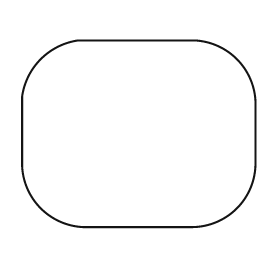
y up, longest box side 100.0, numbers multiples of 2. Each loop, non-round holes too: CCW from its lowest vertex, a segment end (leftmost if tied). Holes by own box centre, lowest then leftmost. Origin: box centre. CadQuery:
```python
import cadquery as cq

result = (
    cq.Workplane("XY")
    .moveTo(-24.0, -40.0)
    .lineTo(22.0, -40.0)
    .threePointArc((42.0, -32.0), (50.0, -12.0))
    .lineTo(50.0, 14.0)
    .threePointArc((42.0, 32.0), (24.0, 40.0))
    .lineTo(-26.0, 40.0)
    .threePointArc((-42.0, 32.0), (-50.0, 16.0))
    .lineTo(-50.0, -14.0)
    .threePointArc((-42.0, -32.0), (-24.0, -40.0))
    .close()
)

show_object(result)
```